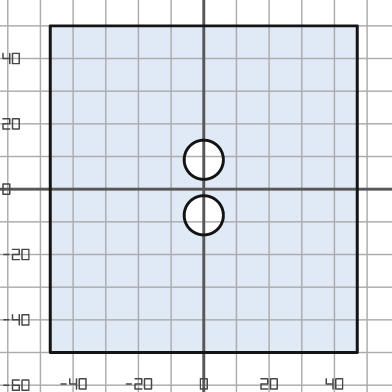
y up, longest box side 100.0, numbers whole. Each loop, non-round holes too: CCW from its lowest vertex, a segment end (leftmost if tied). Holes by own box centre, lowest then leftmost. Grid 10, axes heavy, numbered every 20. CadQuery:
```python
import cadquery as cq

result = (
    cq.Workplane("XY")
    .moveTo(-47.0, -50.0)
    .lineTo(47.0, -50.0)
    .lineTo(47.0, 50.0)
    .lineTo(-47.0, 50.0)
    .close()
    .moveTo(0.0, -8.0)
    .circle(6.0)
    .moveTo(0.0, 9.0)
    .circle(6.0)
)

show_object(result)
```